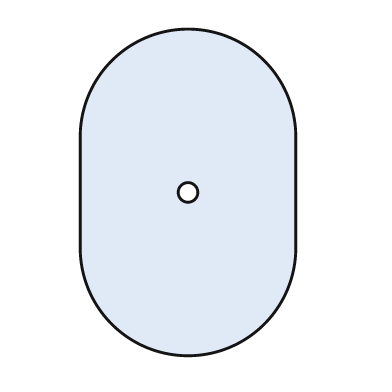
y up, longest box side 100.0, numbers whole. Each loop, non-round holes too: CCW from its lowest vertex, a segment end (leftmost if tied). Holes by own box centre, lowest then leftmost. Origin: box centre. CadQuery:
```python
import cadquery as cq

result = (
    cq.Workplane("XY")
    .moveTo(-33.0, -17.0)
    .threePointArc((0.0, -50.0), (33.0, -17.0))
    .lineTo(33.0, 17.0)
    .threePointArc((0.0, 50.0), (-33.0, 17.0))
    .close()
    .moveTo(0.0, 0.0)
    .circle(3.0)
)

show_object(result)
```